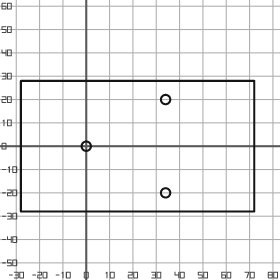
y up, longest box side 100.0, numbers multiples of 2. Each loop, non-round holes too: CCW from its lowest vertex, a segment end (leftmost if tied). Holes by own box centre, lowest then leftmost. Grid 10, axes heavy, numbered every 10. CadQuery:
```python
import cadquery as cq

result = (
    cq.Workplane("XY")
    .moveTo(-28.0, -28.0)
    .lineTo(72.0, -28.0)
    .lineTo(72.0, 28.0)
    .lineTo(-28.0, 28.0)
    .close()
    .moveTo(34.0, -20.0)
    .circle(2.0)
    .moveTo(0.0, 0.0)
    .circle(2.0)
    .moveTo(34.0, 20.0)
    .circle(2.0)
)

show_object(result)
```